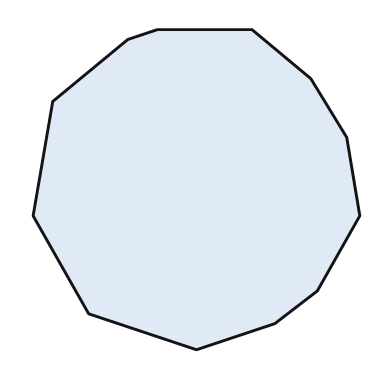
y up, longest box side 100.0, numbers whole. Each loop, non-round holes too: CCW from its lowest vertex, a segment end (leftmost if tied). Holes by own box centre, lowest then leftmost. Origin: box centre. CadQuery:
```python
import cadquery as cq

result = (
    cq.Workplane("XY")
    .moveTo(0.0, -49.0)
    .lineTo(24.0, -41.0)
    .lineTo(37.0, -31.0)
    .lineTo(50.0, -8.0)
    .lineTo(46.0, 16.0)
    .lineTo(35.0, 34.0)
    .lineTo(17.0, 49.0)
    .lineTo(-12.0, 49.0)
    .lineTo(-21.0, 46.0)
    .lineTo(-44.0, 27.0)
    .lineTo(-50.0, -8.0)
    .lineTo(-33.0, -38.0)
    .close()
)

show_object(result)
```